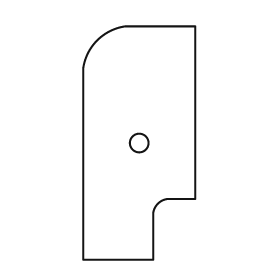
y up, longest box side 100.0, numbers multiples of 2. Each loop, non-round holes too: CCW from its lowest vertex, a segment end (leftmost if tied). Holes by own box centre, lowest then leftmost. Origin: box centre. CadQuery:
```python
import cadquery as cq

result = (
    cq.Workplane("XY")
    .moveTo(-24.0, -50.0)
    .lineTo(6.0, -50.0)
    .lineTo(6.0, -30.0)
    .threePointArc((8.0, -26.0), (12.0, -24.0))
    .lineTo(24.0, -24.0)
    .lineTo(24.0, 50.0)
    .lineTo(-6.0, 50.0)
    .threePointArc((-18.0, 44.0), (-24.0, 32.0))
    .close()
    .moveTo(0.0, 0.0)
    .circle(4.0)
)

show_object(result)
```